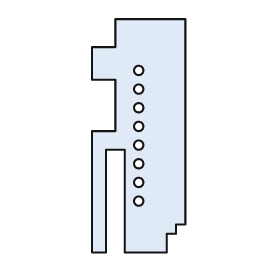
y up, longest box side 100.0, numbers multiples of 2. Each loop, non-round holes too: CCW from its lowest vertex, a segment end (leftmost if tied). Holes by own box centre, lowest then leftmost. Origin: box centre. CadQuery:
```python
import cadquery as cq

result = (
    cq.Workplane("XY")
    .moveTo(-20.0, -50.0)
    .lineTo(-14.0, -50.0)
    .lineTo(-14.0, -6.0)
    .lineTo(-6.0, -6.0)
    .lineTo(-6.0, -50.0)
    .lineTo(12.0, -50.0)
    .lineTo(12.0, -42.0)
    .lineTo(16.0, -42.0)
    .lineTo(16.0, -38.0)
    .lineTo(20.0, -38.0)
    .lineTo(20.0, 50.0)
    .lineTo(-10.0, 50.0)
    .lineTo(-10.0, 38.0)
    .lineTo(-20.0, 38.0)
    .lineTo(-20.0, 24.0)
    .lineTo(-10.0, 24.0)
    .lineTo(-10.0, 2.0)
    .lineTo(-20.0, 2.0)
    .close()
    .moveTo(0.0, -28.0)
    .circle(2.0)
    .moveTo(0.0, -20.0)
    .circle(2.0)
    .moveTo(0.0, -12.0)
    .circle(2.0)
    .moveTo(0.0, -4.0)
    .circle(2.0)
    .moveTo(0.0, 4.0)
    .circle(2.0)
    .moveTo(0.0, 12.0)
    .circle(2.0)
    .moveTo(0.0, 20.0)
    .circle(2.0)
    .moveTo(0.0, 28.0)
    .circle(2.0)
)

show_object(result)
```